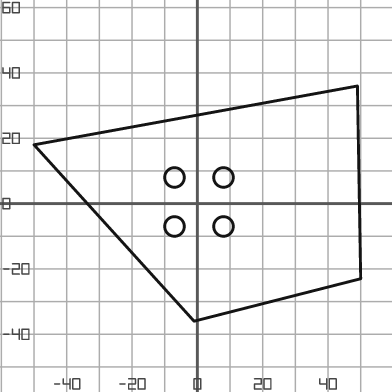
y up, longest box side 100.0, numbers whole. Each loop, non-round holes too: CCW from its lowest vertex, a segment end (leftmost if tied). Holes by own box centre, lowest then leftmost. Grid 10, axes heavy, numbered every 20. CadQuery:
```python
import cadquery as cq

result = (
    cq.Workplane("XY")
    .moveTo(-1.0, -36.0)
    .lineTo(50.0, -23.0)
    .lineTo(49.0, 36.0)
    .lineTo(-50.0, 18.0)
    .close()
    .moveTo(-7.0, -7.0)
    .circle(3.0)
    .moveTo(8.0, -7.0)
    .circle(3.0)
    .moveTo(-7.0, 8.0)
    .circle(3.0)
    .moveTo(8.0, 8.0)
    .circle(3.0)
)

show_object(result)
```